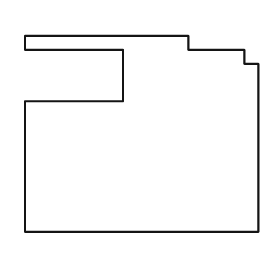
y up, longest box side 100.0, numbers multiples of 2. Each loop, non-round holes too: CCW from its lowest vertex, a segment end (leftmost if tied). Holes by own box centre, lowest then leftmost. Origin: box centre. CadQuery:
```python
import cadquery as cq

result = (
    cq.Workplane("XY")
    .moveTo(-50.0, -42.0)
    .lineTo(50.0, -42.0)
    .lineTo(50.0, 30.0)
    .lineTo(44.0, 30.0)
    .lineTo(44.0, 36.0)
    .lineTo(20.0, 36.0)
    .lineTo(20.0, 42.0)
    .lineTo(-50.0, 42.0)
    .lineTo(-50.0, 36.0)
    .lineTo(-8.0, 36.0)
    .lineTo(-8.0, 14.0)
    .lineTo(-50.0, 14.0)
    .close()
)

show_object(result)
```